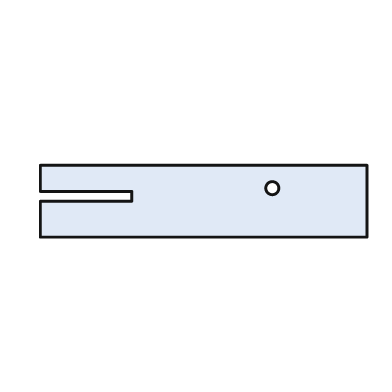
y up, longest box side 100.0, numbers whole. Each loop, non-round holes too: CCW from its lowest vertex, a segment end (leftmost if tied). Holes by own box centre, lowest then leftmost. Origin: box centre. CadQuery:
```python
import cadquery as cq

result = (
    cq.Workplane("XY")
    .moveTo(-50.0, -11.0)
    .lineTo(50.0, -11.0)
    .lineTo(50.0, 11.0)
    .lineTo(-50.0, 11.0)
    .lineTo(-50.0, 3.0)
    .lineTo(-22.0, 3.0)
    .lineTo(-22.0, 0.0)
    .lineTo(-50.0, 0.0)
    .close()
    .moveTo(21.0, 4.0)
    .circle(2.0)
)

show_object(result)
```